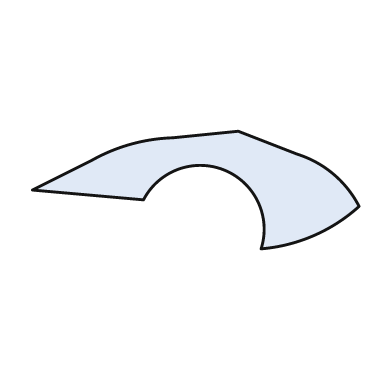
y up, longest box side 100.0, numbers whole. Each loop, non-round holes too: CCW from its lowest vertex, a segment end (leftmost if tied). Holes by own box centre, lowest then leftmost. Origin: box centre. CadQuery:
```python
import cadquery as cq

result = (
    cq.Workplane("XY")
    .moveTo(20.0, -18.0)
    .threePointArc((36.0, -14.0), (50.0, -5.0))
    .threePointArc((42.0, 5.0), (31.0, 11.0))
    .lineTo(13.0, 18.0)
    .lineTo(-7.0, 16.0)
    .threePointArc((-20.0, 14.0), (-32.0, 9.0))
    .lineTo(-50.0, 0.0)
    .lineTo(-16.0, -3.0)
    .threePointArc((9.0, 6.0), (20.0, -18.0))
    .close()
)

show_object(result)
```